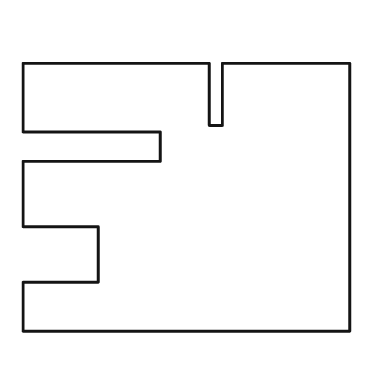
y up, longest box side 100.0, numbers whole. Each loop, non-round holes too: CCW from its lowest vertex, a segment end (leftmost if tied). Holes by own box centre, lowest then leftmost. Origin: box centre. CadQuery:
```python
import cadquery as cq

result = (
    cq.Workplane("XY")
    .moveTo(-50.0, -41.0)
    .lineTo(50.0, -41.0)
    .lineTo(50.0, 41.0)
    .lineTo(11.0, 41.0)
    .lineTo(11.0, 22.0)
    .lineTo(7.0, 22.0)
    .lineTo(7.0, 41.0)
    .lineTo(-50.0, 41.0)
    .lineTo(-50.0, 20.0)
    .lineTo(-8.0, 20.0)
    .lineTo(-8.0, 11.0)
    .lineTo(-50.0, 11.0)
    .lineTo(-50.0, -9.0)
    .lineTo(-27.0, -9.0)
    .lineTo(-27.0, -26.0)
    .lineTo(-50.0, -26.0)
    .close()
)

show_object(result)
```